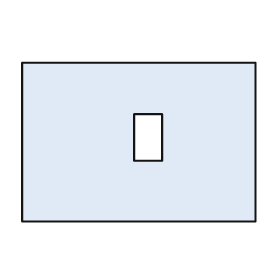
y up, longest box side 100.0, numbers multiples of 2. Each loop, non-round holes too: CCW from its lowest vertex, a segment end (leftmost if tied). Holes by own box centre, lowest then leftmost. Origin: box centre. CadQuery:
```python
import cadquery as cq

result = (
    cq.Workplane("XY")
    .moveTo(-50.0, -34.0)
    .lineTo(50.0, -34.0)
    .lineTo(50.0, 34.0)
    .lineTo(-50.0, 34.0)
    .close()
    .moveTo(-2.0, -8.0)
    .lineTo(10.0, -8.0)
    .lineTo(10.0, 12.0)
    .lineTo(-2.0, 12.0)
    .close()
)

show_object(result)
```